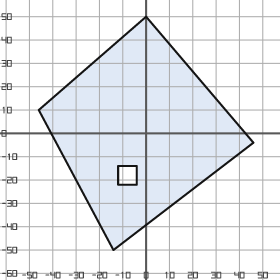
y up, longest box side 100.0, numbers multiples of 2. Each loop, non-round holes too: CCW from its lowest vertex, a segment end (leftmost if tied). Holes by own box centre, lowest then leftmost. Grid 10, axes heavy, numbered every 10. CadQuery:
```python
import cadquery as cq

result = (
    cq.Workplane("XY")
    .moveTo(-14.0, -50.0)
    .lineTo(46.0, -4.0)
    .lineTo(0.0, 50.0)
    .lineTo(-46.0, 10.0)
    .close()
    .moveTo(-12.0, -22.0)
    .lineTo(-4.0, -22.0)
    .lineTo(-4.0, -14.0)
    .lineTo(-12.0, -14.0)
    .close()
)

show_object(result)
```